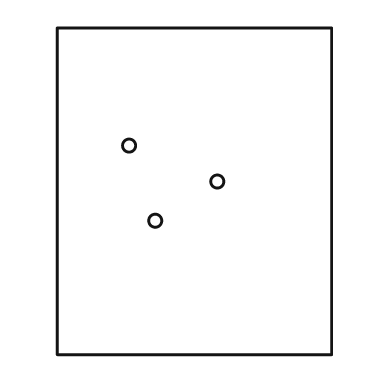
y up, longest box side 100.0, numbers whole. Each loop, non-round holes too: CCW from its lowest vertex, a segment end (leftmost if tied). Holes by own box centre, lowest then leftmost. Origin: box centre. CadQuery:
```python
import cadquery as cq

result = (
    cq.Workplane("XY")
    .moveTo(-42.0, -50.0)
    .lineTo(42.0, -50.0)
    .lineTo(42.0, 50.0)
    .lineTo(-42.0, 50.0)
    .close()
    .moveTo(-12.0, -9.0)
    .circle(2.0)
    .moveTo(7.0, 3.0)
    .circle(2.0)
    .moveTo(-20.0, 14.0)
    .circle(2.0)
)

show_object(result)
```